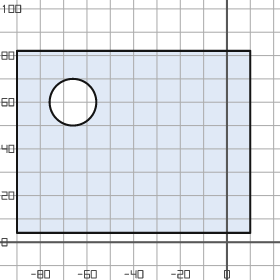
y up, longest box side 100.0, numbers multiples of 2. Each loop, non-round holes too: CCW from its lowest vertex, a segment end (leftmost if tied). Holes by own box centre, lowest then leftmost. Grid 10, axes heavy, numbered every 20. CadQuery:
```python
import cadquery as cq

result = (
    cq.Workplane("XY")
    .moveTo(-90.0, 4.0)
    .lineTo(10.0, 4.0)
    .lineTo(10.0, 82.0)
    .lineTo(-90.0, 82.0)
    .close()
    .moveTo(-66.0, 60.0)
    .circle(10.0)
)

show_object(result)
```